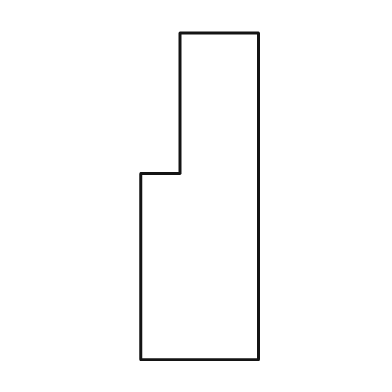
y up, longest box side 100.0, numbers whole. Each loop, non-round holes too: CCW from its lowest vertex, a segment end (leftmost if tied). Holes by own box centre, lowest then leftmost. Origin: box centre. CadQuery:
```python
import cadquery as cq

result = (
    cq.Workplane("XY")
    .moveTo(-18.0, -50.0)
    .lineTo(18.0, -50.0)
    .lineTo(18.0, 50.0)
    .lineTo(-6.0, 50.0)
    .lineTo(-6.0, 7.0)
    .lineTo(-18.0, 7.0)
    .close()
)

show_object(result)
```